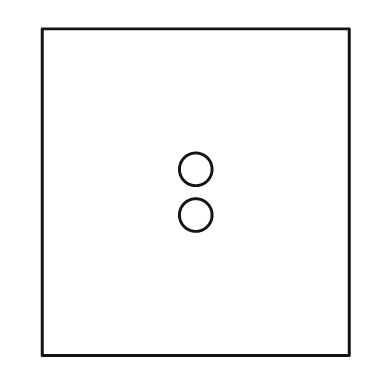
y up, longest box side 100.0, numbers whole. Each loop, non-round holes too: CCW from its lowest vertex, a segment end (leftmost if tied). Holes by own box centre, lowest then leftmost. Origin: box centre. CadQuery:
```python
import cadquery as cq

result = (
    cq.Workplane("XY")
    .moveTo(-47.0, -50.0)
    .lineTo(47.0, -50.0)
    .lineTo(47.0, 50.0)
    .lineTo(-47.0, 50.0)
    .close()
    .moveTo(0.0, -7.0)
    .circle(5.0)
    .moveTo(0.0, 7.0)
    .circle(5.0)
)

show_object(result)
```